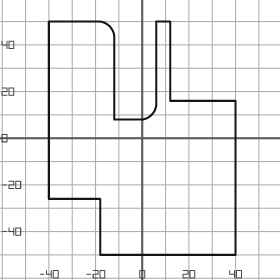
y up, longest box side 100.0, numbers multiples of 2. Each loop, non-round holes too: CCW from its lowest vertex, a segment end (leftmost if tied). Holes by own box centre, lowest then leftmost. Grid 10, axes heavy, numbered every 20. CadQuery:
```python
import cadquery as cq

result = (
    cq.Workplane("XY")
    .moveTo(-18.0, -50.0)
    .lineTo(40.0, -50.0)
    .lineTo(40.0, 16.0)
    .lineTo(12.0, 16.0)
    .lineTo(12.0, 50.0)
    .lineTo(6.0, 50.0)
    .lineTo(6.0, 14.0)
    .threePointArc((4.0, 10.0), (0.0, 8.0))
    .lineTo(-12.0, 8.0)
    .lineTo(-12.0, 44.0)
    .threePointArc((-14.0, 48.0), (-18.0, 50.0))
    .lineTo(-40.0, 50.0)
    .lineTo(-40.0, -26.0)
    .lineTo(-18.0, -26.0)
    .close()
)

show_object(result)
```